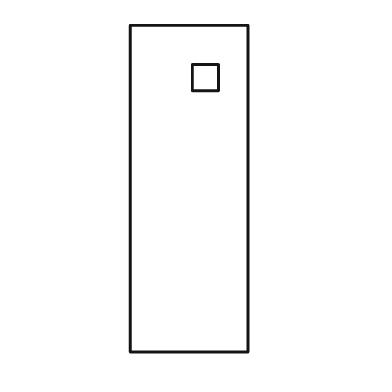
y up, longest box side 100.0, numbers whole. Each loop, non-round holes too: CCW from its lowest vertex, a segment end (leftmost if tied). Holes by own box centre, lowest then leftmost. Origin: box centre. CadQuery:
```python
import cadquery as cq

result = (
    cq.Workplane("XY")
    .moveTo(-18.0, -50.0)
    .lineTo(18.0, -50.0)
    .lineTo(18.0, 50.0)
    .lineTo(-18.0, 50.0)
    .close()
    .moveTo(1.0, 30.0)
    .lineTo(9.0, 30.0)
    .lineTo(9.0, 38.0)
    .lineTo(1.0, 38.0)
    .close()
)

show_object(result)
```